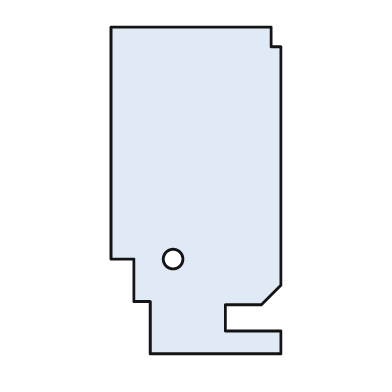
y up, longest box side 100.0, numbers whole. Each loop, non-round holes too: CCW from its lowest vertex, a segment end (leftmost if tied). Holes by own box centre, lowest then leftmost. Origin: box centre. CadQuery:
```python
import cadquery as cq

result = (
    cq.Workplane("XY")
    .moveTo(-14.0, -50.0)
    .lineTo(26.0, -50.0)
    .lineTo(26.0, -43.0)
    .lineTo(9.0, -43.0)
    .lineTo(9.0, -35.0)
    .lineTo(20.0, -35.0)
    .lineTo(26.0, -29.0)
    .lineTo(26.0, 44.0)
    .lineTo(23.0, 44.0)
    .lineTo(23.0, 50.0)
    .lineTo(-26.0, 50.0)
    .lineTo(-26.0, -21.0)
    .lineTo(-19.0, -21.0)
    .lineTo(-19.0, -34.0)
    .lineTo(-14.0, -34.0)
    .close()
    .moveTo(-7.0, -21.0)
    .circle(3.0)
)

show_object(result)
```